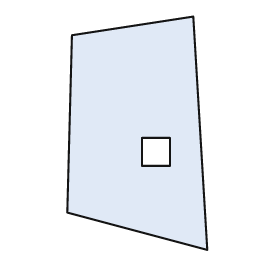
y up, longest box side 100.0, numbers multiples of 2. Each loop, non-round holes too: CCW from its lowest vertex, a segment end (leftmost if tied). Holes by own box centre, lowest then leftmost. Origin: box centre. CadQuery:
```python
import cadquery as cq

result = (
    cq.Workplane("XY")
    .moveTo(30.0, -50.0)
    .lineTo(24.0, 50.0)
    .lineTo(-28.0, 42.0)
    .lineTo(-30.0, -34.0)
    .close()
    .moveTo(2.0, -14.0)
    .lineTo(14.0, -14.0)
    .lineTo(14.0, -2.0)
    .lineTo(2.0, -2.0)
    .close()
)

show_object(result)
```